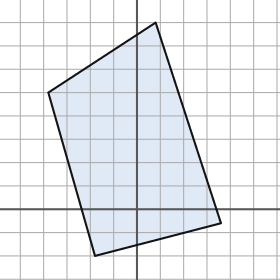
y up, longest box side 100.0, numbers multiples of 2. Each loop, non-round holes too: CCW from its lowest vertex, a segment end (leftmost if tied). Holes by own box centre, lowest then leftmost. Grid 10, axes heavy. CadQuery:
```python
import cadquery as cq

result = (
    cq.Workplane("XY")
    .moveTo(-18.0, -20.0)
    .lineTo(36.0, -6.0)
    .lineTo(8.0, 80.0)
    .lineTo(-38.0, 50.0)
    .close()
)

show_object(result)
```